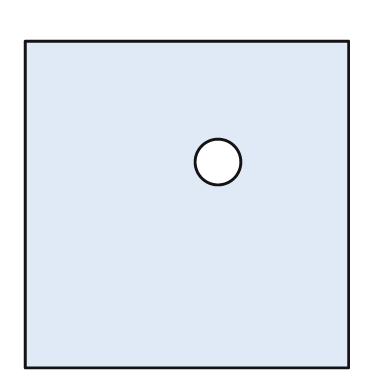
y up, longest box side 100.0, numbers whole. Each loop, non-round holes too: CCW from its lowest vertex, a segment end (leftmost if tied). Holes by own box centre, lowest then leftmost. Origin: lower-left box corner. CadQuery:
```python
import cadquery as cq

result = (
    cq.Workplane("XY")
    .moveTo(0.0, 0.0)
    .lineTo(99.0, 0.0)
    .lineTo(99.0, 100.0)
    .lineTo(0.0, 100.0)
    .close()
    .moveTo(59.0, 63.0)
    .circle(7.0)
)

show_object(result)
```